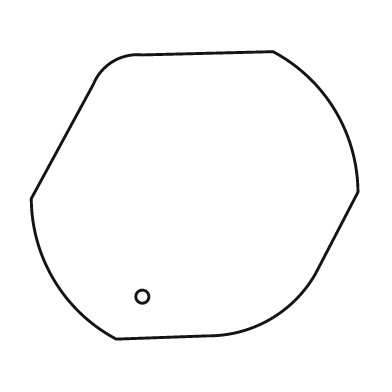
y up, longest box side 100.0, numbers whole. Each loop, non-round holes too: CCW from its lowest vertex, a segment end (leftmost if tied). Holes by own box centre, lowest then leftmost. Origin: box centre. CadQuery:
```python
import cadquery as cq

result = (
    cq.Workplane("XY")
    .moveTo(-24.0, -44.0)
    .lineTo(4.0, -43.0)
    .threePointArc((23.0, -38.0), (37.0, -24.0))
    .lineTo(50.0, 1.0)
    .threePointArc((43.0, 26.0), (24.0, 44.0))
    .lineTo(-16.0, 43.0)
    .threePointArc((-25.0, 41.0), (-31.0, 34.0))
    .lineTo(-50.0, -1.0)
    .threePointArc((-43.0, -26.0), (-24.0, -44.0))
    .close()
    .moveTo(-16.0, -31.0)
    .circle(2.0)
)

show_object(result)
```